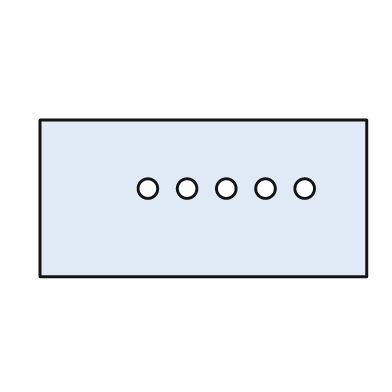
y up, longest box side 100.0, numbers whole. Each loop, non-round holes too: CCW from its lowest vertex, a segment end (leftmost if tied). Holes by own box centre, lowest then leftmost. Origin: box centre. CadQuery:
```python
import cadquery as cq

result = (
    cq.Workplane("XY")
    .moveTo(-50.0, -24.0)
    .lineTo(50.0, -24.0)
    .lineTo(50.0, 24.0)
    .lineTo(-50.0, 24.0)
    .close()
    .moveTo(-17.0, 3.0)
    .circle(3.0)
    .moveTo(-5.0, 3.0)
    .circle(3.0)
    .moveTo(7.0, 3.0)
    .circle(3.0)
    .moveTo(19.0, 3.0)
    .circle(3.0)
    .moveTo(31.0, 3.0)
    .circle(3.0)
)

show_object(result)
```